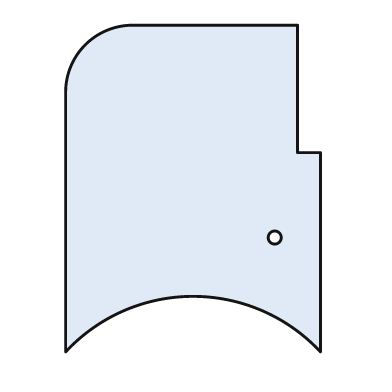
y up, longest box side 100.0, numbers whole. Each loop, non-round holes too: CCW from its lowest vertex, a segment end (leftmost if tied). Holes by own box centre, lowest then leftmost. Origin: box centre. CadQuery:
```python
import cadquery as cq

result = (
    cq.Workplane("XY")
    .moveTo(-39.0, -50.0)
    .threePointArc((0.0, -33.0), (39.0, -50.0))
    .lineTo(39.0, 11.0)
    .lineTo(32.0, 11.0)
    .lineTo(32.0, 50.0)
    .lineTo(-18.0, 50.0)
    .threePointArc((-33.0, 44.0), (-39.0, 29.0))
    .close()
    .moveTo(25.0, -15.0)
    .circle(2.0)
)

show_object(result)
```